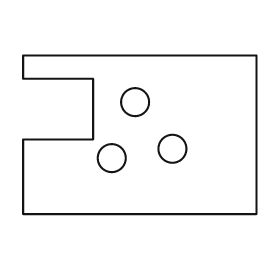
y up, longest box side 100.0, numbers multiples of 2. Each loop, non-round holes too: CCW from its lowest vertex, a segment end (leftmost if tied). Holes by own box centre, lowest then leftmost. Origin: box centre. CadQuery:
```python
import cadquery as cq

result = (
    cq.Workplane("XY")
    .moveTo(-50.0, -34.0)
    .lineTo(50.0, -34.0)
    .lineTo(50.0, 34.0)
    .lineTo(-50.0, 34.0)
    .lineTo(-50.0, 24.0)
    .lineTo(-20.0, 24.0)
    .lineTo(-20.0, -2.0)
    .lineTo(-50.0, -2.0)
    .close()
    .moveTo(-12.0, -10.0)
    .circle(6.0)
    .moveTo(14.0, -6.0)
    .circle(6.0)
    .moveTo(-2.0, 14.0)
    .circle(6.0)
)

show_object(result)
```